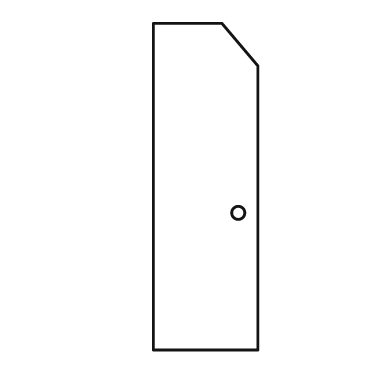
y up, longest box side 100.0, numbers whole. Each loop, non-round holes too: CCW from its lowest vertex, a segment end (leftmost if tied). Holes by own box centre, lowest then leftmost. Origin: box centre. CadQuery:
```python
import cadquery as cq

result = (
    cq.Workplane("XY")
    .moveTo(-16.0, -50.0)
    .lineTo(16.0, -50.0)
    .lineTo(16.0, 37.0)
    .lineTo(5.0, 50.0)
    .lineTo(-16.0, 50.0)
    .close()
    .moveTo(10.0, -8.0)
    .circle(2.0)
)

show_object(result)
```